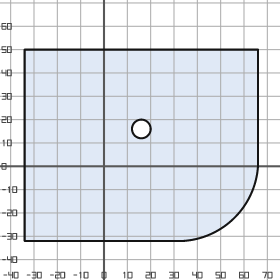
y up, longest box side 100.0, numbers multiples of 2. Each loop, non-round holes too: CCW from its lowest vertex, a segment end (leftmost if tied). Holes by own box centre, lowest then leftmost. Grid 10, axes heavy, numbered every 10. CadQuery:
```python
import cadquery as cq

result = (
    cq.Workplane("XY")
    .moveTo(-34.0, -32.0)
    .lineTo(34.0, -32.0)
    .threePointArc((56.0, -22.0), (66.0, 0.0))
    .lineTo(66.0, 50.0)
    .lineTo(-34.0, 50.0)
    .close()
    .moveTo(16.0, 16.0)
    .circle(4.0)
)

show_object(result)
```